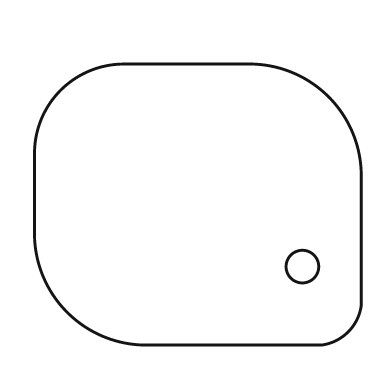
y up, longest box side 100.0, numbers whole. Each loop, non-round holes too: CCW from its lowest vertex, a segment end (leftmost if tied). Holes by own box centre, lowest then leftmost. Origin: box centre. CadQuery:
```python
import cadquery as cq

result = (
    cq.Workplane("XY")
    .moveTo(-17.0, -43.0)
    .lineTo(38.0, -43.0)
    .threePointArc((46.0, -39.0), (50.0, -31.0))
    .lineTo(50.0, 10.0)
    .threePointArc((40.0, 33.0), (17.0, 43.0))
    .lineTo(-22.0, 43.0)
    .threePointArc((-42.0, 35.0), (-50.0, 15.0))
    .lineTo(-50.0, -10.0)
    .threePointArc((-40.0, -33.0), (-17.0, -43.0))
    .close()
    .moveTo(32.0, -19.0)
    .circle(5.0)
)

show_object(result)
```